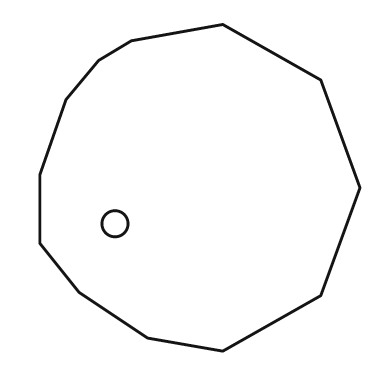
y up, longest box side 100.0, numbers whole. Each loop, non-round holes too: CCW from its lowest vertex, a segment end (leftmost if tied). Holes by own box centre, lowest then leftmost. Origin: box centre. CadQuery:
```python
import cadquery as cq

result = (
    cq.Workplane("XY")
    .moveTo(7.0, -50.0)
    .lineTo(37.0, -33.0)
    .lineTo(49.0, 0.0)
    .lineTo(37.0, 33.0)
    .lineTo(7.0, 50.0)
    .lineTo(-21.0, 45.0)
    .lineTo(-31.0, 39.0)
    .lineTo(-41.0, 27.0)
    .lineTo(-49.0, 4.0)
    .lineTo(-49.0, -17.0)
    .lineTo(-37.0, -32.0)
    .lineTo(-16.0, -46.0)
    .close()
    .moveTo(-26.0, -11.0)
    .circle(4.0)
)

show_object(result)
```